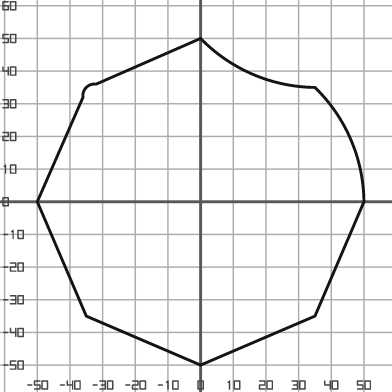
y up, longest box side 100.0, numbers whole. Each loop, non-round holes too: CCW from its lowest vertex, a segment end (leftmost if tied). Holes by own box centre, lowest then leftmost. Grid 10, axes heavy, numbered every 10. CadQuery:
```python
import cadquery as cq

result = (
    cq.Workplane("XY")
    .moveTo(0.0, -50.0)
    .lineTo(35.0, -35.0)
    .lineTo(50.0, 0.0)
    .threePointArc((46.0, 19.0), (35.0, 35.0))
    .threePointArc((16.0, 39.0), (0.0, 50.0))
    .lineTo(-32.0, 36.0)
    .threePointArc((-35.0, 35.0), (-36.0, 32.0))
    .lineTo(-50.0, 0.0)
    .lineTo(-35.0, -35.0)
    .close()
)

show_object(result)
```